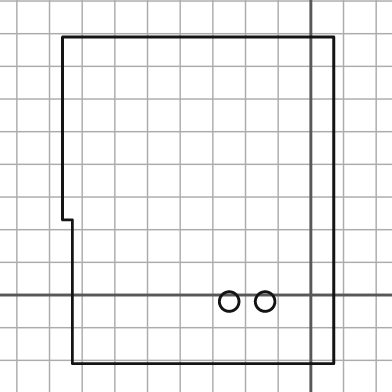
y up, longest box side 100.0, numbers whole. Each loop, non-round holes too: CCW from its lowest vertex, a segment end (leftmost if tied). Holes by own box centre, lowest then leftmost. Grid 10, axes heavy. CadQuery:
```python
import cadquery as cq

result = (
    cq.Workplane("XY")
    .moveTo(-73.0, -21.0)
    .lineTo(7.0, -21.0)
    .lineTo(7.0, 79.0)
    .lineTo(-76.0, 79.0)
    .lineTo(-76.0, 23.0)
    .lineTo(-73.0, 23.0)
    .close()
    .moveTo(-25.0, -2.0)
    .circle(3.0)
    .moveTo(-14.0, -2.0)
    .circle(3.0)
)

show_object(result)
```